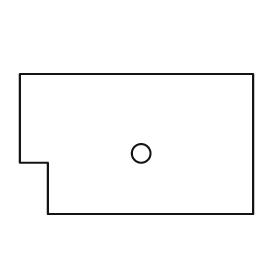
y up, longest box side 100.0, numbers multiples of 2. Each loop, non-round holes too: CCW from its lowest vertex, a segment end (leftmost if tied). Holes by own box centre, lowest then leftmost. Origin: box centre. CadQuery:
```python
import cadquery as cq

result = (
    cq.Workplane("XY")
    .moveTo(-38.0, -30.0)
    .lineTo(50.0, -30.0)
    .lineTo(50.0, 30.0)
    .lineTo(-50.0, 30.0)
    .lineTo(-50.0, -8.0)
    .lineTo(-38.0, -8.0)
    .close()
    .moveTo(2.0, -4.0)
    .circle(4.0)
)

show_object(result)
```